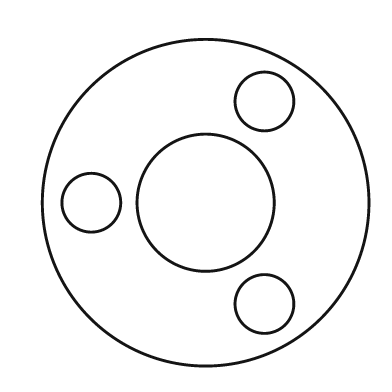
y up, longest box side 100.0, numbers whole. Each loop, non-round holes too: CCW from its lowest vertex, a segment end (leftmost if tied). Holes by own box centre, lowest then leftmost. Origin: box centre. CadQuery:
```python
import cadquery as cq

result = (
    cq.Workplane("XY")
    .moveTo(0.0, 0.0)
    .circle(50.0)
    .moveTo(18.0, -31.0)
    .circle(9.0)
    .moveTo(-35.0, 0.0)
    .circle(9.0)
    .moveTo(0.0, 0.0)
    .circle(21.0)
    .moveTo(18.0, 31.0)
    .circle(9.0)
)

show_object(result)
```